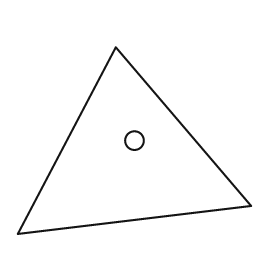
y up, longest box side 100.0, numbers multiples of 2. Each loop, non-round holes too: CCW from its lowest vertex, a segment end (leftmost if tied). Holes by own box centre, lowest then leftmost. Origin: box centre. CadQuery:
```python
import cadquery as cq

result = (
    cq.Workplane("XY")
    .moveTo(-50.0, -40.0)
    .lineTo(50.0, -28.0)
    .lineTo(-8.0, 40.0)
    .close()
    .moveTo(0.0, 0.0)
    .circle(4.0)
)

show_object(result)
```